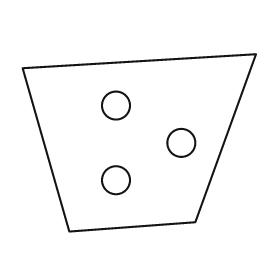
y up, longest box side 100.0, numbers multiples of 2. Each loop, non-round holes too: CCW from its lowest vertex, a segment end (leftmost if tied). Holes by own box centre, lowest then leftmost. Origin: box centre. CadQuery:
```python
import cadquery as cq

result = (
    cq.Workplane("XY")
    .moveTo(-30.0, -38.0)
    .lineTo(24.0, -34.0)
    .lineTo(50.0, 38.0)
    .lineTo(-50.0, 32.0)
    .close()
    .moveTo(-10.0, -16.0)
    .circle(6.0)
    .moveTo(18.0, 0.0)
    .circle(6.0)
    .moveTo(-10.0, 16.0)
    .circle(6.0)
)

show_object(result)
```